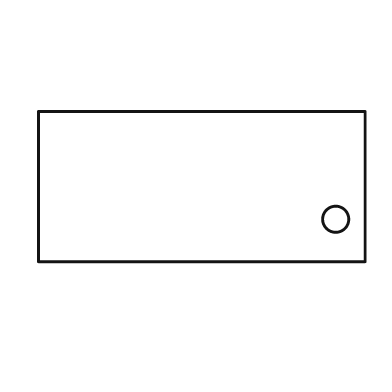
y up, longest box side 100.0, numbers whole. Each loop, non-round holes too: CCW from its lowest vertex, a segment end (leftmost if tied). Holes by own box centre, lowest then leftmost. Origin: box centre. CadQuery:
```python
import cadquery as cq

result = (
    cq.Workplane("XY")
    .moveTo(-50.0, -23.0)
    .lineTo(50.0, -23.0)
    .lineTo(50.0, 23.0)
    .lineTo(-50.0, 23.0)
    .close()
    .moveTo(41.0, -10.0)
    .circle(4.0)
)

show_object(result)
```